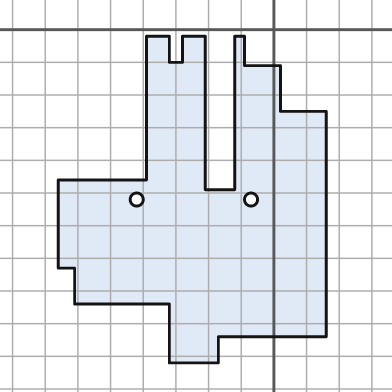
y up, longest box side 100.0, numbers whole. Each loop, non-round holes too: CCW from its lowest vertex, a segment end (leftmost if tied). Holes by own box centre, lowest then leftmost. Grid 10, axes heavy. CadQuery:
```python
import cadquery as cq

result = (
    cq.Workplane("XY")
    .moveTo(-32.0, -102.0)
    .lineTo(-17.0, -102.0)
    .lineTo(-17.0, -94.0)
    .lineTo(16.0, -94.0)
    .lineTo(16.0, -25.0)
    .lineTo(2.0, -25.0)
    .lineTo(2.0, -11.0)
    .lineTo(-9.0, -11.0)
    .lineTo(-9.0, -2.0)
    .lineTo(-12.0, -2.0)
    .lineTo(-12.0, -49.0)
    .lineTo(-21.0, -49.0)
    .lineTo(-21.0, -2.0)
    .lineTo(-28.0, -2.0)
    .lineTo(-28.0, -10.0)
    .lineTo(-32.0, -10.0)
    .lineTo(-32.0, -2.0)
    .lineTo(-39.0, -2.0)
    .lineTo(-39.0, -46.0)
    .lineTo(-66.0, -46.0)
    .lineTo(-66.0, -73.0)
    .lineTo(-61.0, -73.0)
    .lineTo(-61.0, -84.0)
    .lineTo(-32.0, -84.0)
    .close()
    .moveTo(-42.0, -52.0)
    .circle(2.0)
    .moveTo(-7.0, -52.0)
    .circle(2.0)
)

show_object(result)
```